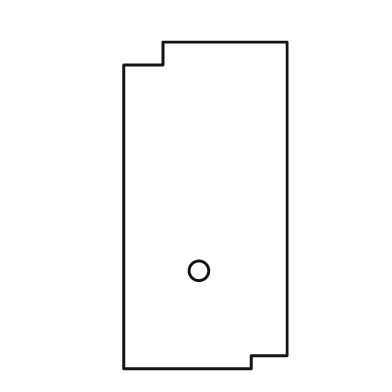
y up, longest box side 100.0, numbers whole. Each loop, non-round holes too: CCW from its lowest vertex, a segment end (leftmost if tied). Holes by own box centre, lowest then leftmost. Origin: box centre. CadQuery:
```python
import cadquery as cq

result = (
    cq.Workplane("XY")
    .moveTo(-25.0, -50.0)
    .lineTo(14.0, -50.0)
    .lineTo(14.0, -46.0)
    .lineTo(25.0, -46.0)
    .lineTo(25.0, 50.0)
    .lineTo(-13.0, 50.0)
    .lineTo(-13.0, 43.0)
    .lineTo(-25.0, 43.0)
    .close()
    .moveTo(-2.0, -20.0)
    .circle(3.0)
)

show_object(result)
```